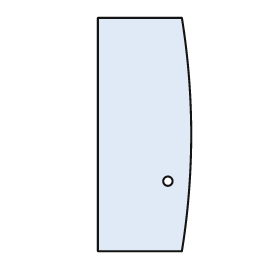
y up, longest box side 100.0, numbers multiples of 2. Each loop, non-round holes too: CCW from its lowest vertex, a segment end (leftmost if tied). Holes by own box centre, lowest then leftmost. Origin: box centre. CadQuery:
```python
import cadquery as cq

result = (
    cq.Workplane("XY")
    .moveTo(-20.0, -50.0)
    .lineTo(16.0, -50.0)
    .threePointArc((20.0, 0.0), (16.0, 50.0))
    .lineTo(-20.0, 50.0)
    .close()
    .moveTo(10.0, -20.0)
    .circle(2.0)
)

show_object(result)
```